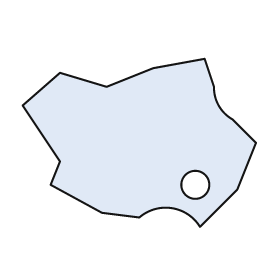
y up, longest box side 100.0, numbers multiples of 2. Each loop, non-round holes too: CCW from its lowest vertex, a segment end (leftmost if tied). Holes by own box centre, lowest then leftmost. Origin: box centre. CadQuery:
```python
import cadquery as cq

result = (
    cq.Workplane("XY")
    .moveTo(26.0, -36.0)
    .lineTo(42.0, -20.0)
    .lineTo(50.0, 0.0)
    .lineTo(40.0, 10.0)
    .threePointArc((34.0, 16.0), (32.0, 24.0))
    .lineTo(28.0, 36.0)
    .lineTo(6.0, 32.0)
    .lineTo(-14.0, 24.0)
    .lineTo(-34.0, 30.0)
    .lineTo(-50.0, 16.0)
    .lineTo(-34.0, -8.0)
    .lineTo(-38.0, -18.0)
    .lineTo(-16.0, -30.0)
    .lineTo(0.0, -32.0)
    .threePointArc((14.0, -28.0), (26.0, -36.0))
    .close()
    .moveTo(24.0, -18.0)
    .circle(6.0)
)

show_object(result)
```